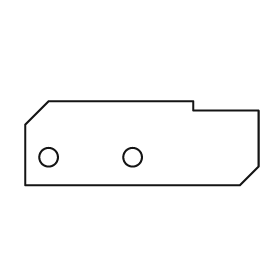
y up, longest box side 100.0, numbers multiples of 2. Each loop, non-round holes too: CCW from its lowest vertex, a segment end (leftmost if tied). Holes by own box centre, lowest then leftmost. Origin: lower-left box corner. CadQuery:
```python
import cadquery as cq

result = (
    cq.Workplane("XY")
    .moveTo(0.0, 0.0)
    .lineTo(92.0, 0.0)
    .lineTo(100.0, 8.0)
    .lineTo(100.0, 32.0)
    .lineTo(72.0, 32.0)
    .lineTo(72.0, 36.0)
    .lineTo(10.0, 36.0)
    .lineTo(0.0, 26.0)
    .close()
    .moveTo(10.0, 12.0)
    .circle(4.0)
    .moveTo(46.0, 12.0)
    .circle(4.0)
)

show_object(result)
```